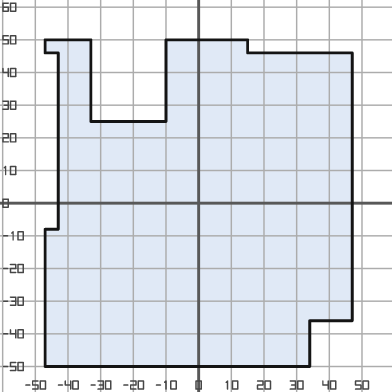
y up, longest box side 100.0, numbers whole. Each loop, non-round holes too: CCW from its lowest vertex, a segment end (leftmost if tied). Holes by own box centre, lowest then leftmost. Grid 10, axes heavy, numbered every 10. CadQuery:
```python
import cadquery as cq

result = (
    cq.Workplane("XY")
    .moveTo(-47.0, -50.0)
    .lineTo(34.0, -50.0)
    .lineTo(34.0, -36.0)
    .lineTo(47.0, -36.0)
    .lineTo(47.0, 46.0)
    .lineTo(15.0, 46.0)
    .lineTo(15.0, 50.0)
    .lineTo(-10.0, 50.0)
    .lineTo(-10.0, 25.0)
    .lineTo(-33.0, 25.0)
    .lineTo(-33.0, 50.0)
    .lineTo(-47.0, 50.0)
    .lineTo(-47.0, 46.0)
    .lineTo(-43.0, 46.0)
    .lineTo(-43.0, -8.0)
    .lineTo(-47.0, -8.0)
    .close()
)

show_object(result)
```